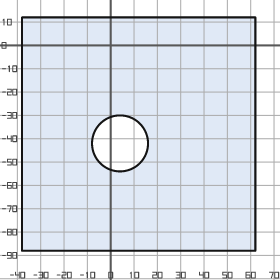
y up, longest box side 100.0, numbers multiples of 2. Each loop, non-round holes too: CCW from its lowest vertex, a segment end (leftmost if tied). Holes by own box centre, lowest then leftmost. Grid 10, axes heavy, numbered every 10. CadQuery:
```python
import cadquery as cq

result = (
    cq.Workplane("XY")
    .moveTo(-38.0, -88.0)
    .lineTo(62.0, -88.0)
    .lineTo(62.0, 12.0)
    .lineTo(-38.0, 12.0)
    .close()
    .moveTo(4.0, -42.0)
    .circle(12.0)
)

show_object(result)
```